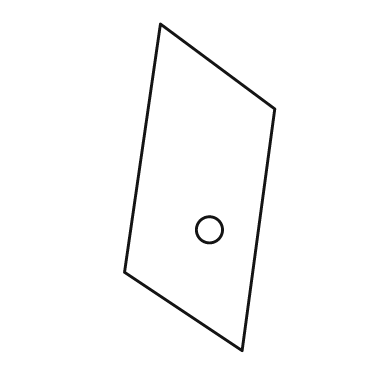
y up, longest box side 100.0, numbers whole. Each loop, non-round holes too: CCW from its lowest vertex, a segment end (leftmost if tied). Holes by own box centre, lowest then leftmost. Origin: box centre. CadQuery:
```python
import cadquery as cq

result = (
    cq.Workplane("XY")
    .moveTo(13.0, -50.0)
    .lineTo(23.0, 24.0)
    .lineTo(-12.0, 50.0)
    .lineTo(-23.0, -26.0)
    .close()
    .moveTo(3.0, -13.0)
    .circle(4.0)
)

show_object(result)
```